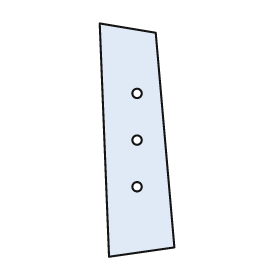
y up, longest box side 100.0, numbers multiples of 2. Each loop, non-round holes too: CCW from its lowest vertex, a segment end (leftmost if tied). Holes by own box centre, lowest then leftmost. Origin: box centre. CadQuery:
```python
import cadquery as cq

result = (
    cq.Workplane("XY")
    .moveTo(-12.0, -50.0)
    .lineTo(16.0, -46.0)
    .lineTo(8.0, 46.0)
    .lineTo(-16.0, 50.0)
    .close()
    .moveTo(0.0, -20.0)
    .circle(2.0)
    .moveTo(0.0, 0.0)
    .circle(2.0)
    .moveTo(0.0, 20.0)
    .circle(2.0)
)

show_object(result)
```